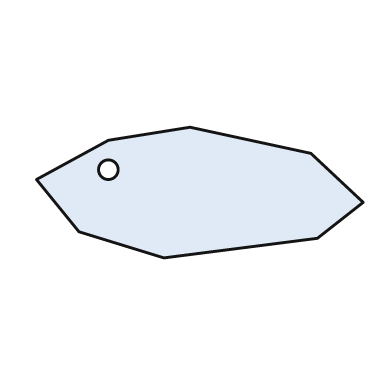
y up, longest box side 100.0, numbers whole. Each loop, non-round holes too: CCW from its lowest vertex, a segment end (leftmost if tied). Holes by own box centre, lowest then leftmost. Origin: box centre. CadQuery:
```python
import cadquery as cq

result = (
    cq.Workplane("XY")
    .moveTo(-11.0, -20.0)
    .lineTo(36.0, -14.0)
    .lineTo(50.0, -3.0)
    .lineTo(34.0, 12.0)
    .lineTo(-3.0, 20.0)
    .lineTo(-28.0, 16.0)
    .lineTo(-50.0, 4.0)
    .lineTo(-37.0, -12.0)
    .close()
    .moveTo(-28.0, 7.0)
    .circle(3.0)
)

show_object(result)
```